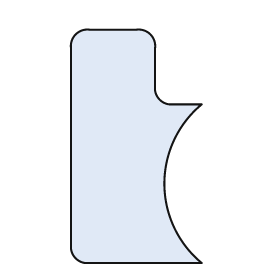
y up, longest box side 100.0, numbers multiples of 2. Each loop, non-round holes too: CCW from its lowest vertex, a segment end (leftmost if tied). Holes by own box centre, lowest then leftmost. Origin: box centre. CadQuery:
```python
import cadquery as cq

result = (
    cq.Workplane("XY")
    .moveTo(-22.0, -50.0)
    .lineTo(28.0, -50.0)
    .threePointArc((12.0, -16.0), (28.0, 18.0))
    .lineTo(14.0, 18.0)
    .threePointArc((10.0, 20.0), (8.0, 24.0))
    .lineTo(8.0, 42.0)
    .threePointArc((6.0, 48.0), (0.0, 50.0))
    .lineTo(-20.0, 50.0)
    .threePointArc((-26.0, 48.0), (-28.0, 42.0))
    .lineTo(-28.0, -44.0)
    .threePointArc((-26.0, -48.0), (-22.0, -50.0))
    .close()
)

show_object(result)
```